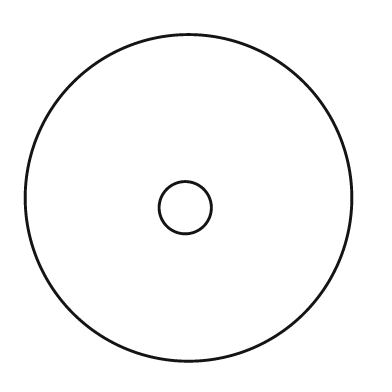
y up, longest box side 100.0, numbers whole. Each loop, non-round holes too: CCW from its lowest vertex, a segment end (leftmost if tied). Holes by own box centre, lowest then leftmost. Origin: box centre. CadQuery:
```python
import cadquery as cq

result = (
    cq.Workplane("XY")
    .moveTo(0.0, 0.0)
    .circle(50.0)
    .moveTo(-1.0, -3.0)
    .circle(8.0)
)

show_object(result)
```